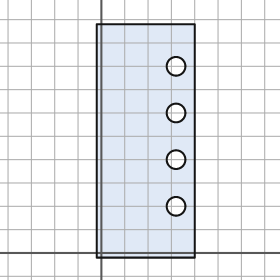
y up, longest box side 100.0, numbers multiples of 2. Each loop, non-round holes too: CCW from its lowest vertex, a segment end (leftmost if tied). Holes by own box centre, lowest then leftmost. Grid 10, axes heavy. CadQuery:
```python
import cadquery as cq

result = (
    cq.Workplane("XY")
    .moveTo(-2.0, -2.0)
    .lineTo(40.0, -2.0)
    .lineTo(40.0, 98.0)
    .lineTo(-2.0, 98.0)
    .close()
    .moveTo(32.0, 20.0)
    .circle(4.0)
    .moveTo(32.0, 40.0)
    .circle(4.0)
    .moveTo(32.0, 60.0)
    .circle(4.0)
    .moveTo(32.0, 80.0)
    .circle(4.0)
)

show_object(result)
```